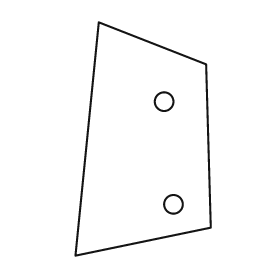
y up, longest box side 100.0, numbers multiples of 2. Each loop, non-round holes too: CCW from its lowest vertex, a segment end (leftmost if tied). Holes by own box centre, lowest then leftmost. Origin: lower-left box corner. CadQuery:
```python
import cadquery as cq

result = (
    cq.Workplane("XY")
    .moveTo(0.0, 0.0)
    .lineTo(58.0, 12.0)
    .lineTo(56.0, 82.0)
    .lineTo(10.0, 100.0)
    .close()
    .moveTo(42.0, 22.0)
    .circle(4.0)
    .moveTo(38.0, 66.0)
    .circle(4.0)
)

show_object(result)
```